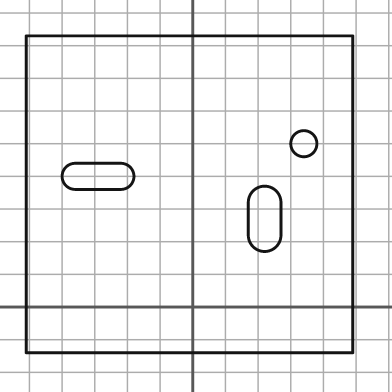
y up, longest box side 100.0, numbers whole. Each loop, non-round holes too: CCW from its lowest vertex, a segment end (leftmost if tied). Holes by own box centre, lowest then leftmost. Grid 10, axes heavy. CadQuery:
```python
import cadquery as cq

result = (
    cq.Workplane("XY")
    .moveTo(-51.0, -14.0)
    .lineTo(49.0, -14.0)
    .lineTo(49.0, 83.0)
    .lineTo(-51.0, 83.0)
    .close()
    .moveTo(17.0, 22.0)
    .threePointArc((22.0, 17.0), (27.0, 22.0))
    .lineTo(27.0, 32.0)
    .threePointArc((22.0, 37.0), (17.0, 32.0))
    .close()
    .moveTo(-36.0, 36.0)
    .lineTo(-22.0, 36.0)
    .threePointArc((-18.0, 40.0), (-22.0, 44.0))
    .lineTo(-36.0, 44.0)
    .threePointArc((-40.0, 40.0), (-36.0, 36.0))
    .close()
    .moveTo(34.0, 50.0)
    .circle(4.0)
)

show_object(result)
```